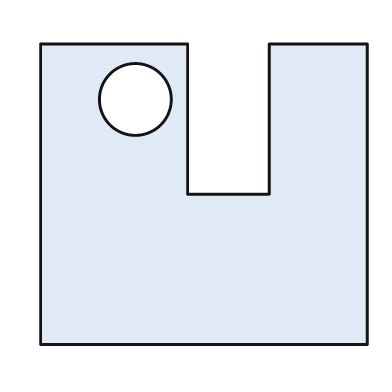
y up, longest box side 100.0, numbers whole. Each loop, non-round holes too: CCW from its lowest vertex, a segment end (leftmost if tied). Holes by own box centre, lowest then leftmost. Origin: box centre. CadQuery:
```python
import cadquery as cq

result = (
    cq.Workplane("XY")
    .moveTo(-50.0, -46.0)
    .lineTo(50.0, -46.0)
    .lineTo(50.0, 46.0)
    .lineTo(20.0, 46.0)
    .lineTo(20.0, 0.0)
    .lineTo(-5.0, 0.0)
    .lineTo(-5.0, 46.0)
    .lineTo(-50.0, 46.0)
    .close()
    .moveTo(-21.0, 29.0)
    .circle(11.0)
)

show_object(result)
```